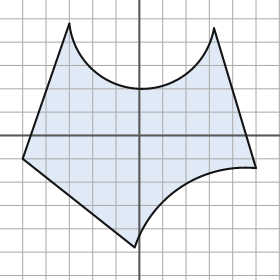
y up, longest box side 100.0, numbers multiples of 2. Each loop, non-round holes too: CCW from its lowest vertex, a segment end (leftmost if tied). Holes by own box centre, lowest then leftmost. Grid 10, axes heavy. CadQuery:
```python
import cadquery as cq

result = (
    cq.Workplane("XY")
    .moveTo(-2.0, -48.0)
    .threePointArc((18.0, -22.0), (50.0, -14.0))
    .lineTo(32.0, 46.0)
    .threePointArc((0.0, 20.0), (-30.0, 48.0))
    .lineTo(-50.0, -10.0)
    .close()
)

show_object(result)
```